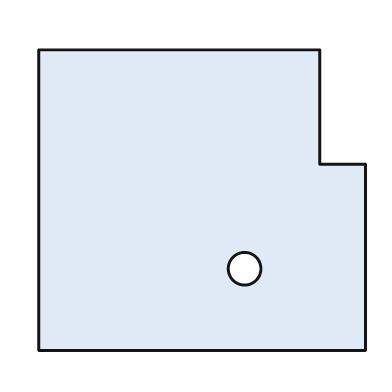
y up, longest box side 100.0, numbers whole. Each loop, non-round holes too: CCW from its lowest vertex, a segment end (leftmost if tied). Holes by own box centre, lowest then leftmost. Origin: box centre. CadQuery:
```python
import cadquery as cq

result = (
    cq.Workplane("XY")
    .moveTo(-50.0, -46.0)
    .lineTo(50.0, -46.0)
    .lineTo(50.0, 11.0)
    .lineTo(36.0, 11.0)
    .lineTo(36.0, 46.0)
    .lineTo(-50.0, 46.0)
    .close()
    .moveTo(13.0, -21.0)
    .circle(5.0)
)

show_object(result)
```